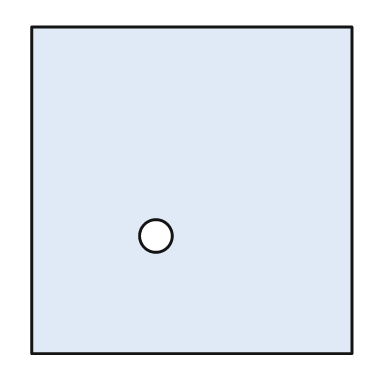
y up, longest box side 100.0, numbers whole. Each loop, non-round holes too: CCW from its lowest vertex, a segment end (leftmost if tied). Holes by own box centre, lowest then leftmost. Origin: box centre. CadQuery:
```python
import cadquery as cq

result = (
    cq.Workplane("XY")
    .moveTo(-49.0, -50.0)
    .lineTo(49.0, -50.0)
    .lineTo(49.0, 50.0)
    .lineTo(-49.0, 50.0)
    .close()
    .moveTo(-11.0, -14.0)
    .circle(5.0)
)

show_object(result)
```